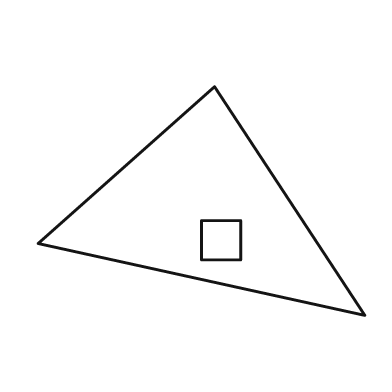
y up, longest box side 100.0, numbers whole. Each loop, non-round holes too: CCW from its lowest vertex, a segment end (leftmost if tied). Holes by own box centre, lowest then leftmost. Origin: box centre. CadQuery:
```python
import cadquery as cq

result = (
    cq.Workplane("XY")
    .moveTo(50.0, -35.0)
    .lineTo(4.0, 35.0)
    .lineTo(-50.0, -13.0)
    .close()
    .moveTo(0.0, -18.0)
    .lineTo(12.0, -18.0)
    .lineTo(12.0, -6.0)
    .lineTo(0.0, -6.0)
    .close()
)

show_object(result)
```